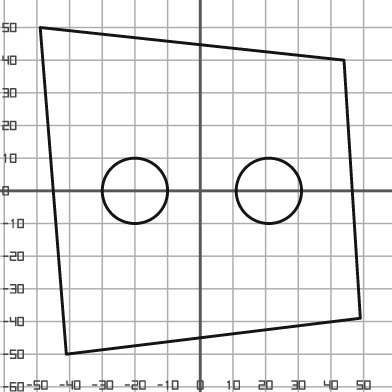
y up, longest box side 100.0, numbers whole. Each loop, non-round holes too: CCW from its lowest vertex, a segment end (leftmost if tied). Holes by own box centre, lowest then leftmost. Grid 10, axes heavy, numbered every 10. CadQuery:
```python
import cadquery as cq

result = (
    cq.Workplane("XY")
    .moveTo(-41.0, -50.0)
    .lineTo(49.0, -39.0)
    .lineTo(44.0, 40.0)
    .lineTo(-49.0, 50.0)
    .close()
    .moveTo(-20.0, 0.0)
    .circle(10.0)
    .moveTo(21.0, 0.0)
    .circle(10.0)
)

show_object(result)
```